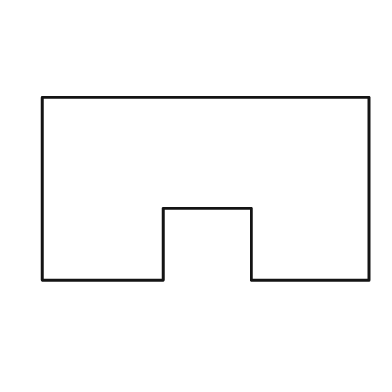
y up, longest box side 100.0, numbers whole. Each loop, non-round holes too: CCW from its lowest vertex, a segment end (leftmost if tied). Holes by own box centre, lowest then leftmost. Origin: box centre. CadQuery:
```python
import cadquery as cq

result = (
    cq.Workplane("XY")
    .moveTo(-50.0, -28.0)
    .lineTo(-13.0, -28.0)
    .lineTo(-13.0, -6.0)
    .lineTo(14.0, -6.0)
    .lineTo(14.0, -28.0)
    .lineTo(50.0, -28.0)
    .lineTo(50.0, 28.0)
    .lineTo(-50.0, 28.0)
    .close()
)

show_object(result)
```